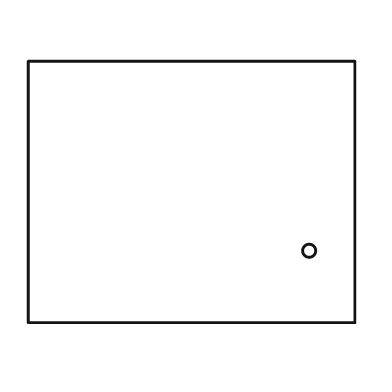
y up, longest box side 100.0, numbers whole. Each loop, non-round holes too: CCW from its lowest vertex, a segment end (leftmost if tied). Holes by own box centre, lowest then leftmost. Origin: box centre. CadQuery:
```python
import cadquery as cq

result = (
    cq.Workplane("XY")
    .moveTo(-50.0, -40.0)
    .lineTo(50.0, -40.0)
    .lineTo(50.0, 40.0)
    .lineTo(-50.0, 40.0)
    .close()
    .moveTo(36.0, -18.0)
    .circle(2.0)
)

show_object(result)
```